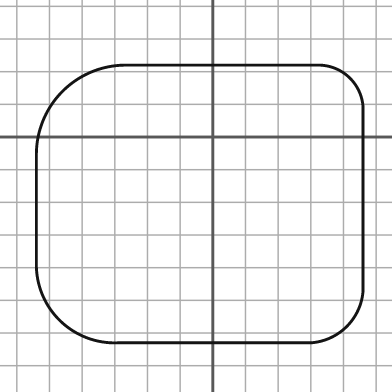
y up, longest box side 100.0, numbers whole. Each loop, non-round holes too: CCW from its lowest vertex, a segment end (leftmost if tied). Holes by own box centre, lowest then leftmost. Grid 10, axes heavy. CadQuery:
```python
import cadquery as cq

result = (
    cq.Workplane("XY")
    .moveTo(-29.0, -63.0)
    .lineTo(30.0, -63.0)
    .threePointArc((41.0, -58.0), (46.0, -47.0))
    .lineTo(46.0, 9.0)
    .threePointArc((42.0, 18.0), (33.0, 22.0))
    .lineTo(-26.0, 22.0)
    .threePointArc((-46.0, 14.0), (-54.0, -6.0))
    .lineTo(-54.0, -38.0)
    .threePointArc((-47.0, -56.0), (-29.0, -63.0))
    .close()
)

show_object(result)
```